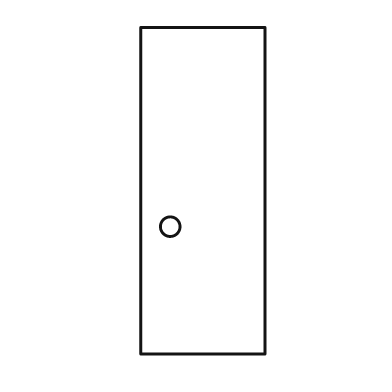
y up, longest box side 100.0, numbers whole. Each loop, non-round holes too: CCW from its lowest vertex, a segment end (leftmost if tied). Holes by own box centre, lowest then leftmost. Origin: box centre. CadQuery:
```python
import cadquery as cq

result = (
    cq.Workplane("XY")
    .moveTo(-19.0, -50.0)
    .lineTo(19.0, -50.0)
    .lineTo(19.0, 50.0)
    .lineTo(-19.0, 50.0)
    .close()
    .moveTo(-10.0, -11.0)
    .circle(3.0)
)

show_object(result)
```